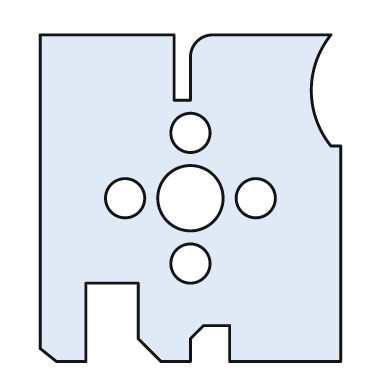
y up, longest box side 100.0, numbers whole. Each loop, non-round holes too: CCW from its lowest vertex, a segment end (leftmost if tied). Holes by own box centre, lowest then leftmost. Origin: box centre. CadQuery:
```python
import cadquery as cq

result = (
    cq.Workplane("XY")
    .moveTo(-41.0, -50.0)
    .lineTo(-32.0, -50.0)
    .lineTo(-32.0, -26.0)
    .lineTo(-16.0, -26.0)
    .lineTo(-16.0, -43.0)
    .lineTo(-9.0, -50.0)
    .lineTo(0.0, -50.0)
    .lineTo(0.0, -43.0)
    .lineTo(4.0, -39.0)
    .lineTo(12.0, -39.0)
    .lineTo(12.0, -50.0)
    .lineTo(46.0, -50.0)
    .lineTo(46.0, 16.0)
    .lineTo(43.0, 16.0)
    .threePointArc((37.0, 33.0), (43.0, 50.0))
    .lineTo(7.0, 50.0)
    .threePointArc((2.0, 48.0), (0.0, 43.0))
    .lineTo(0.0, 30.0)
    .lineTo(-5.0, 30.0)
    .lineTo(-5.0, 50.0)
    .lineTo(-46.0, 50.0)
    .lineTo(-46.0, -46.0)
    .close()
    .moveTo(0.0, -20.0)
    .circle(6.0)
    .moveTo(-20.0, 0.0)
    .circle(6.0)
    .moveTo(0.0, 0.0)
    .circle(10.0)
    .moveTo(20.0, 0.0)
    .circle(6.0)
    .moveTo(0.0, 20.0)
    .circle(6.0)
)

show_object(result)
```